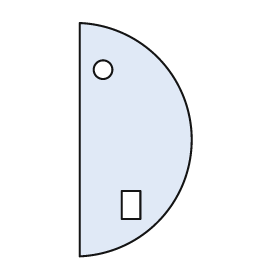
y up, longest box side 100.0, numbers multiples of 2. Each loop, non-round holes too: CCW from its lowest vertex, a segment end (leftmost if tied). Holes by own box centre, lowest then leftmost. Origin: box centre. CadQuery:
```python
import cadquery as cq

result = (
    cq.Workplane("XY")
    .moveTo(-24.0, -50.0)
    .threePointArc((24.0, 0.0), (-24.0, 50.0))
    .close()
    .moveTo(-6.0, -34.0)
    .lineTo(2.0, -34.0)
    .lineTo(2.0, -22.0)
    .lineTo(-6.0, -22.0)
    .close()
    .moveTo(-14.0, 30.0)
    .circle(4.0)
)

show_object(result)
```